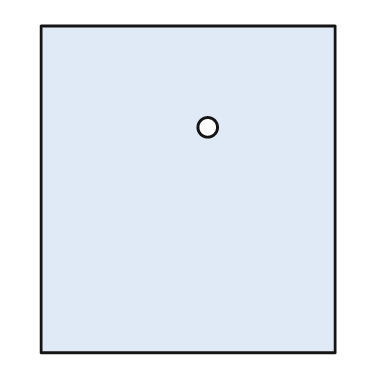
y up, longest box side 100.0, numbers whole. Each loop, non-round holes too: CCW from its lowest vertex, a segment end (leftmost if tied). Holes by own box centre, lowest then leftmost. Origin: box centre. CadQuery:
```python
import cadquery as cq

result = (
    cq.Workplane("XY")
    .moveTo(-45.0, -50.0)
    .lineTo(45.0, -50.0)
    .lineTo(45.0, 50.0)
    .lineTo(-45.0, 50.0)
    .close()
    .moveTo(6.0, 19.0)
    .circle(3.0)
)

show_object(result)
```